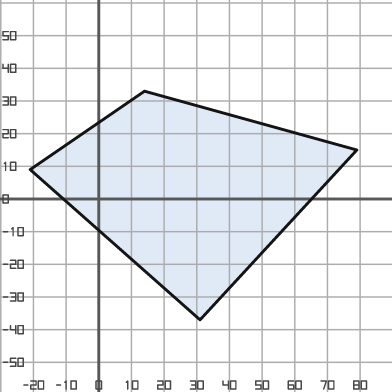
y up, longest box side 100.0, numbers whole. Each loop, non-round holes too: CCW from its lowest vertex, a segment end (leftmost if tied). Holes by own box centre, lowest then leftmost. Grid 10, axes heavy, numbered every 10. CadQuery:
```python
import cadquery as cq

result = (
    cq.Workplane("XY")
    .moveTo(31.0, -37.0)
    .lineTo(79.0, 15.0)
    .lineTo(14.0, 33.0)
    .lineTo(-21.0, 9.0)
    .close()
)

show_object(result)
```